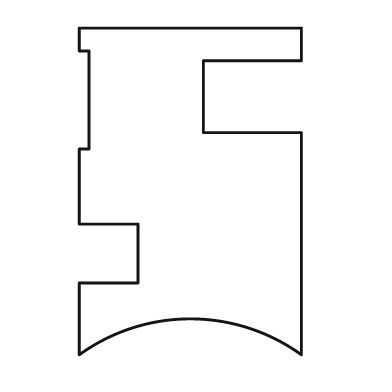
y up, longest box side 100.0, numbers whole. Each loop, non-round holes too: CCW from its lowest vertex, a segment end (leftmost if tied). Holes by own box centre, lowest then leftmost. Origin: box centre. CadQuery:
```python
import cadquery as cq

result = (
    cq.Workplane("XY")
    .moveTo(-34.0, -50.0)
    .threePointArc((0.0, -39.0), (34.0, -50.0))
    .lineTo(34.0, 18.0)
    .lineTo(4.0, 18.0)
    .lineTo(4.0, 40.0)
    .lineTo(34.0, 40.0)
    .lineTo(34.0, 50.0)
    .lineTo(-34.0, 50.0)
    .lineTo(-34.0, 43.0)
    .lineTo(-31.0, 43.0)
    .lineTo(-31.0, 13.0)
    .lineTo(-34.0, 13.0)
    .lineTo(-34.0, -10.0)
    .lineTo(-16.0, -10.0)
    .lineTo(-16.0, -28.0)
    .lineTo(-34.0, -28.0)
    .close()
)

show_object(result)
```